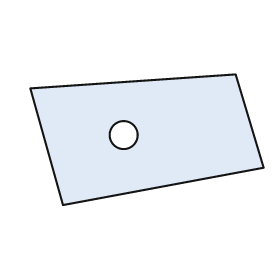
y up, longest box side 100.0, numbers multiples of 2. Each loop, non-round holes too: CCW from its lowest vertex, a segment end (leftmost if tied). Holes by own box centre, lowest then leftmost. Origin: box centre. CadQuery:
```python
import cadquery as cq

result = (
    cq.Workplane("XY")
    .moveTo(-36.0, -28.0)
    .lineTo(50.0, -12.0)
    .lineTo(38.0, 28.0)
    .lineTo(-50.0, 22.0)
    .close()
    .moveTo(-10.0, 2.0)
    .circle(6.0)
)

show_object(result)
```